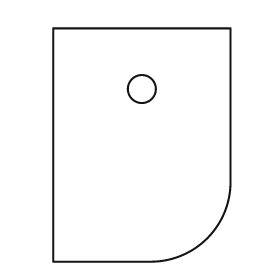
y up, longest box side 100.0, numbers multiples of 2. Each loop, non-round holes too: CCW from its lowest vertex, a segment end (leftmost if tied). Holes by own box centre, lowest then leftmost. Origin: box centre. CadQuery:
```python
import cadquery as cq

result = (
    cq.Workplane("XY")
    .moveTo(-38.0, -50.0)
    .lineTo(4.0, -50.0)
    .threePointArc((28.0, -40.0), (38.0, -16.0))
    .lineTo(38.0, 50.0)
    .lineTo(-38.0, 50.0)
    .close()
    .moveTo(0.0, 24.0)
    .circle(6.0)
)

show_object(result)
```